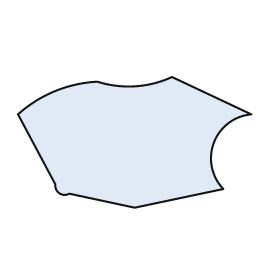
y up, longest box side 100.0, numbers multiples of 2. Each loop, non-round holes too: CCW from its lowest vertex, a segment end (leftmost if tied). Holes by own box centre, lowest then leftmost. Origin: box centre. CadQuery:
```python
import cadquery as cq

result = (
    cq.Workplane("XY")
    .moveTo(0.0, -28.0)
    .lineTo(38.0, -20.0)
    .threePointArc((34.0, 0.0), (50.0, 12.0))
    .lineTo(16.0, 28.0)
    .threePointArc((0.0, 24.0), (-16.0, 26.0))
    .threePointArc((-34.0, 22.0), (-50.0, 12.0))
    .lineTo(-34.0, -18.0)
    .threePointArc((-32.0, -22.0), (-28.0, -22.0))
    .close()
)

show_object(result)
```